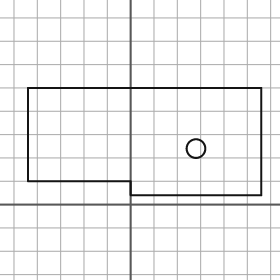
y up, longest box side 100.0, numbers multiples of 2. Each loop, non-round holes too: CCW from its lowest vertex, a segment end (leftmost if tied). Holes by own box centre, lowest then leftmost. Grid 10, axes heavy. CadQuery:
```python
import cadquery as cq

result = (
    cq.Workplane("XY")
    .moveTo(0.0, 4.0)
    .lineTo(56.0, 4.0)
    .lineTo(56.0, 50.0)
    .lineTo(-44.0, 50.0)
    .lineTo(-44.0, 10.0)
    .lineTo(0.0, 10.0)
    .close()
    .moveTo(28.0, 24.0)
    .circle(4.0)
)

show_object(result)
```